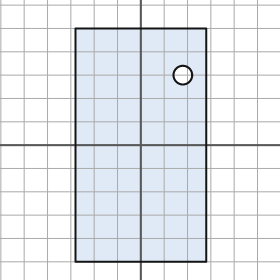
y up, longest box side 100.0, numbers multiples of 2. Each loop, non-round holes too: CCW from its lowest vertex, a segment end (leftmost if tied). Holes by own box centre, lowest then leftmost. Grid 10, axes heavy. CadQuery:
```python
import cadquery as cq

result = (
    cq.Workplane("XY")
    .moveTo(-28.0, -50.0)
    .lineTo(28.0, -50.0)
    .lineTo(28.0, 50.0)
    .lineTo(-28.0, 50.0)
    .close()
    .moveTo(18.0, 30.0)
    .circle(4.0)
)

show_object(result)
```